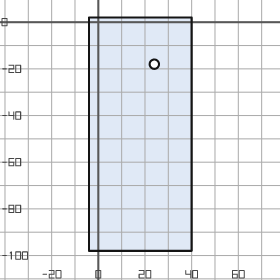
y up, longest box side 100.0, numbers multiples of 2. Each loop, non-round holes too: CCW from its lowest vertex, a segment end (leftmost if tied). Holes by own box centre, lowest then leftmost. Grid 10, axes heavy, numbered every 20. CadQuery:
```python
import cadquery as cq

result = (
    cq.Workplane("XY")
    .moveTo(-4.0, -98.0)
    .lineTo(40.0, -98.0)
    .lineTo(40.0, 2.0)
    .lineTo(-4.0, 2.0)
    .close()
    .moveTo(24.0, -18.0)
    .circle(2.0)
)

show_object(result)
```